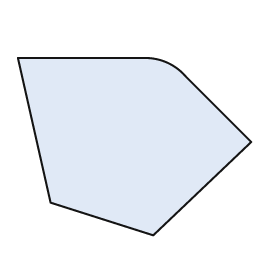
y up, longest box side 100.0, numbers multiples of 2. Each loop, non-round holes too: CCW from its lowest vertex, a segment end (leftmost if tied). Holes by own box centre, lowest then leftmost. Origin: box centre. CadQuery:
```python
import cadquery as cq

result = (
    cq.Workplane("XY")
    .moveTo(8.0, -38.0)
    .lineTo(50.0, 2.0)
    .lineTo(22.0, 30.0)
    .threePointArc((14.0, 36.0), (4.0, 38.0))
    .lineTo(-50.0, 38.0)
    .lineTo(-36.0, -24.0)
    .close()
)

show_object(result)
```